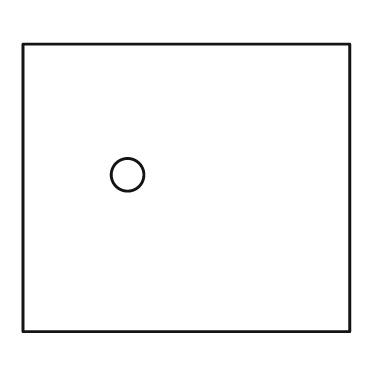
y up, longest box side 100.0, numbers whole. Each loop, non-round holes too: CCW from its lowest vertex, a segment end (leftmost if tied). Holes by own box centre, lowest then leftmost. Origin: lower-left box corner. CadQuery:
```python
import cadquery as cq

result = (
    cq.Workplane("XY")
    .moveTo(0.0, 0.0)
    .lineTo(100.0, 0.0)
    .lineTo(100.0, 88.0)
    .lineTo(0.0, 88.0)
    .close()
    .moveTo(32.0, 48.0)
    .circle(5.0)
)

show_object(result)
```